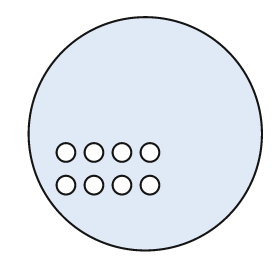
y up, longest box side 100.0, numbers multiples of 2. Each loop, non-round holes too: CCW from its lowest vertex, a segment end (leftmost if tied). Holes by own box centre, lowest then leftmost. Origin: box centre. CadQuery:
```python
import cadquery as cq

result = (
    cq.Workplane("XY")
    .moveTo(0.0, 0.0)
    .circle(50.0)
    .moveTo(-34.0, -22.0)
    .circle(4.0)
    .moveTo(-22.0, -22.0)
    .circle(4.0)
    .moveTo(-10.0, -22.0)
    .circle(4.0)
    .moveTo(2.0, -22.0)
    .circle(4.0)
    .moveTo(-34.0, -8.0)
    .circle(4.0)
    .moveTo(-22.0, -8.0)
    .circle(4.0)
    .moveTo(-10.0, -8.0)
    .circle(4.0)
    .moveTo(2.0, -8.0)
    .circle(4.0)
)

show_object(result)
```